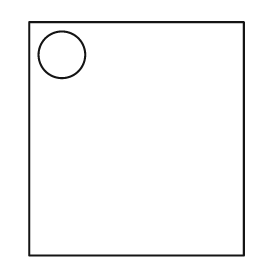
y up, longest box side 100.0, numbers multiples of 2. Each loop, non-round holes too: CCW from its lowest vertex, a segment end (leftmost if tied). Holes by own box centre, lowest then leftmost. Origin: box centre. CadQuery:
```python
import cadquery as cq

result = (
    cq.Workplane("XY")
    .moveTo(-46.0, -50.0)
    .lineTo(46.0, -50.0)
    .lineTo(46.0, 50.0)
    .lineTo(-46.0, 50.0)
    .close()
    .moveTo(-32.0, 36.0)
    .circle(10.0)
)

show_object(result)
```